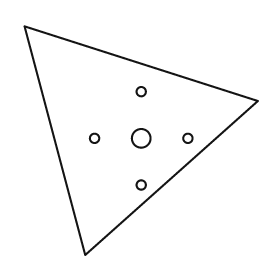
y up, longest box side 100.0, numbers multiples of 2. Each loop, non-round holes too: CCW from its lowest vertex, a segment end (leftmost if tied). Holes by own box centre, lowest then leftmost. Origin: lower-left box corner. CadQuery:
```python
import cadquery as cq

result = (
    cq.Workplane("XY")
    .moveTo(26.0, 0.0)
    .lineTo(100.0, 66.0)
    .lineTo(0.0, 98.0)
    .close()
    .moveTo(50.0, 30.0)
    .circle(2.0)
    .moveTo(30.0, 50.0)
    .circle(2.0)
    .moveTo(50.0, 50.0)
    .circle(4.0)
    .moveTo(70.0, 50.0)
    .circle(2.0)
    .moveTo(50.0, 70.0)
    .circle(2.0)
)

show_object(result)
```